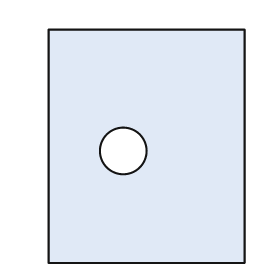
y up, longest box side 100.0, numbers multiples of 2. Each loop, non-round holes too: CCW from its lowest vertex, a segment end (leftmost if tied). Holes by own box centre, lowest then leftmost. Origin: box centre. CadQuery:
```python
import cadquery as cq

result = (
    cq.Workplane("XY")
    .moveTo(-42.0, -50.0)
    .lineTo(42.0, -50.0)
    .lineTo(42.0, 50.0)
    .lineTo(-42.0, 50.0)
    .close()
    .moveTo(-10.0, -2.0)
    .circle(10.0)
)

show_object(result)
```